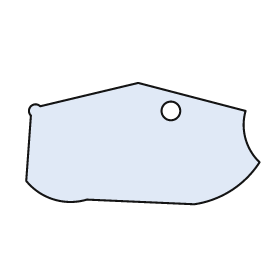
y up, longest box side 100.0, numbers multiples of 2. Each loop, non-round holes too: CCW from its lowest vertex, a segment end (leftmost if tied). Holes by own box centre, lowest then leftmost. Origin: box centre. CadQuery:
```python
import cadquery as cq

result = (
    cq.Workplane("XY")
    .moveTo(22.0, -26.0)
    .threePointArc((38.0, -20.0), (50.0, -8.0))
    .threePointArc((44.0, 2.0), (44.0, 14.0))
    .lineTo(-2.0, 26.0)
    .lineTo(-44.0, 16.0)
    .threePointArc((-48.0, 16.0), (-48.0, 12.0))
    .lineTo(-50.0, -16.0)
    .threePointArc((-38.0, -24.0), (-24.0, -24.0))
    .close()
    .moveTo(12.0, 14.0)
    .circle(4.0)
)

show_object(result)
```